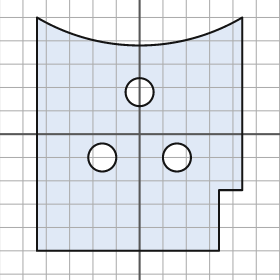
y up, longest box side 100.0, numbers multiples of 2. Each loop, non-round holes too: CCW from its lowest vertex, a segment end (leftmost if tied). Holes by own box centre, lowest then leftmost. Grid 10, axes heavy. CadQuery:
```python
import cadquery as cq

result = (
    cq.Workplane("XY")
    .moveTo(-44.0, -50.0)
    .lineTo(34.0, -50.0)
    .lineTo(34.0, -24.0)
    .lineTo(44.0, -24.0)
    .lineTo(44.0, 50.0)
    .threePointArc((0.0, 38.0), (-44.0, 50.0))
    .close()
    .moveTo(-16.0, -10.0)
    .circle(6.0)
    .moveTo(16.0, -10.0)
    .circle(6.0)
    .moveTo(0.0, 18.0)
    .circle(6.0)
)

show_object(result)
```